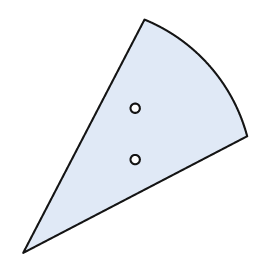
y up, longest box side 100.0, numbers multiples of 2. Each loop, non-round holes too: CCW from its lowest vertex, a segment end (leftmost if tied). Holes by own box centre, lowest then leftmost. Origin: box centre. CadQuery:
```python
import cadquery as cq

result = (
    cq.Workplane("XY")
    .moveTo(-48.0, -50.0)
    .lineTo(48.0, 0.0)
    .threePointArc((32.0, 30.0), (4.0, 50.0))
    .close()
    .moveTo(0.0, -10.0)
    .circle(2.0)
    .moveTo(0.0, 12.0)
    .circle(2.0)
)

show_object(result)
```